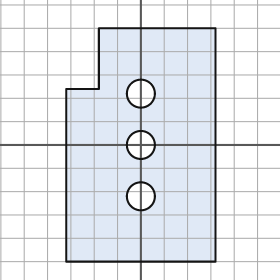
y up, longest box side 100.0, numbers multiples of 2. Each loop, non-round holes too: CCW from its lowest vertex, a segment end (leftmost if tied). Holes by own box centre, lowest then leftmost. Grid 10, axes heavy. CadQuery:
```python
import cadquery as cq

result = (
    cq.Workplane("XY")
    .moveTo(-32.0, -50.0)
    .lineTo(32.0, -50.0)
    .lineTo(32.0, 50.0)
    .lineTo(-18.0, 50.0)
    .lineTo(-18.0, 24.0)
    .lineTo(-32.0, 24.0)
    .close()
    .moveTo(0.0, -22.0)
    .circle(6.0)
    .moveTo(0.0, 0.0)
    .circle(6.0)
    .moveTo(0.0, 22.0)
    .circle(6.0)
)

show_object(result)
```